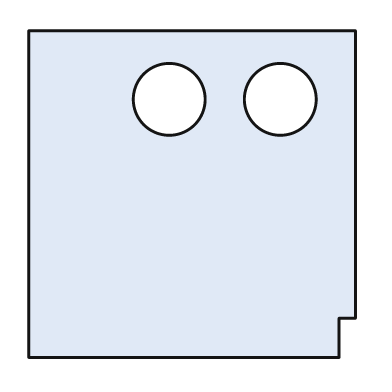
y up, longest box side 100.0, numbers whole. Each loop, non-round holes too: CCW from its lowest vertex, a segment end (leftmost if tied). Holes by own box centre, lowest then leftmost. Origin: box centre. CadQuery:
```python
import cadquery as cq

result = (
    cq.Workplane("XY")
    .moveTo(-50.0, -50.0)
    .lineTo(45.0, -50.0)
    .lineTo(45.0, -38.0)
    .lineTo(50.0, -38.0)
    .lineTo(50.0, 50.0)
    .lineTo(-50.0, 50.0)
    .close()
    .moveTo(-7.0, 29.0)
    .circle(11.0)
    .moveTo(27.0, 29.0)
    .circle(11.0)
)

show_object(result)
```